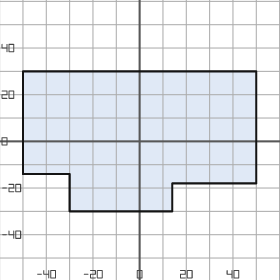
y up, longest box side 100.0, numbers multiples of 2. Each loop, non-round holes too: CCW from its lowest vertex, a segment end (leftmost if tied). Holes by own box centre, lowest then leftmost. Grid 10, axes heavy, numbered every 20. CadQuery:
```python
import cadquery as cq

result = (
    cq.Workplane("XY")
    .moveTo(-30.0, -30.0)
    .lineTo(14.0, -30.0)
    .lineTo(14.0, -18.0)
    .lineTo(50.0, -18.0)
    .lineTo(50.0, 30.0)
    .lineTo(-50.0, 30.0)
    .lineTo(-50.0, -14.0)
    .lineTo(-30.0, -14.0)
    .close()
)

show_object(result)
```